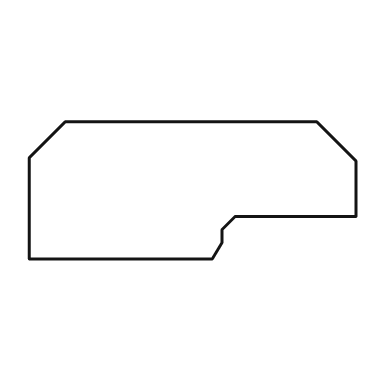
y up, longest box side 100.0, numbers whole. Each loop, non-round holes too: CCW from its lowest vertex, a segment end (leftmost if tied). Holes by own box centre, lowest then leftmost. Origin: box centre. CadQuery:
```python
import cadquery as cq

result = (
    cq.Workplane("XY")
    .moveTo(-50.0, -21.0)
    .lineTo(6.0, -21.0)
    .lineTo(9.0, -16.0)
    .lineTo(9.0, -12.0)
    .lineTo(13.0, -8.0)
    .lineTo(50.0, -8.0)
    .lineTo(50.0, 9.0)
    .lineTo(38.0, 21.0)
    .lineTo(-39.0, 21.0)
    .lineTo(-50.0, 10.0)
    .close()
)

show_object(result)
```